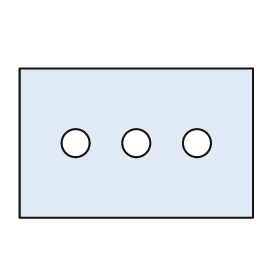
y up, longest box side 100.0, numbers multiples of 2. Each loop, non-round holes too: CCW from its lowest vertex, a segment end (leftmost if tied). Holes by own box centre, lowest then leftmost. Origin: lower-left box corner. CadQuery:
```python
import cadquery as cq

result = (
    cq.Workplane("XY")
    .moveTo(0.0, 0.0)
    .lineTo(100.0, 0.0)
    .lineTo(100.0, 64.0)
    .lineTo(0.0, 64.0)
    .close()
    .moveTo(24.0, 32.0)
    .circle(6.0)
    .moveTo(50.0, 32.0)
    .circle(6.0)
    .moveTo(76.0, 32.0)
    .circle(6.0)
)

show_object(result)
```